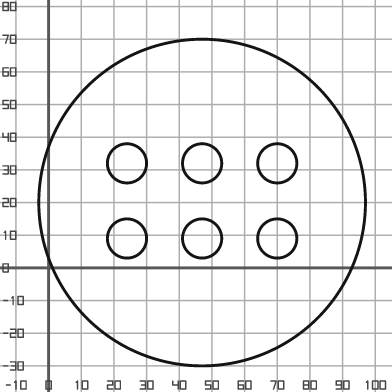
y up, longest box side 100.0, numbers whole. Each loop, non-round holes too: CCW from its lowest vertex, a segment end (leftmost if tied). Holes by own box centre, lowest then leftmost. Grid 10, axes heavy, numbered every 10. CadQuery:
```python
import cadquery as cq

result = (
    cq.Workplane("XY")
    .moveTo(47.0, 20.0)
    .circle(50.0)
    .moveTo(24.0, 9.0)
    .circle(6.0)
    .moveTo(47.0, 9.0)
    .circle(6.0)
    .moveTo(70.0, 9.0)
    .circle(6.0)
    .moveTo(24.0, 32.0)
    .circle(6.0)
    .moveTo(47.0, 32.0)
    .circle(6.0)
    .moveTo(70.0, 32.0)
    .circle(6.0)
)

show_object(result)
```